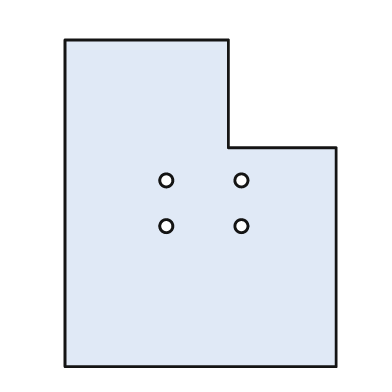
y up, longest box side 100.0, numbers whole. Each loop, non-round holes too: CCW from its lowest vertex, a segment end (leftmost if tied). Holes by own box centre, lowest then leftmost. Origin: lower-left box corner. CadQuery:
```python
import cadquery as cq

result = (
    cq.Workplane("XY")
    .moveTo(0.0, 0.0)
    .lineTo(83.0, 0.0)
    .lineTo(83.0, 67.0)
    .lineTo(50.0, 67.0)
    .lineTo(50.0, 100.0)
    .lineTo(0.0, 100.0)
    .close()
    .moveTo(31.0, 43.0)
    .circle(2.0)
    .moveTo(54.0, 43.0)
    .circle(2.0)
    .moveTo(31.0, 57.0)
    .circle(2.0)
    .moveTo(54.0, 57.0)
    .circle(2.0)
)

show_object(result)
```